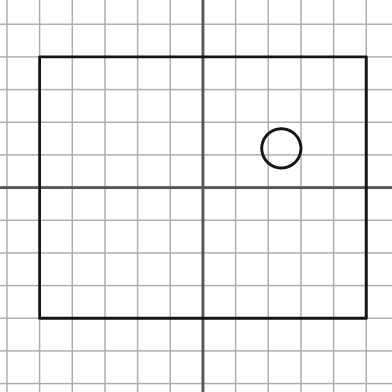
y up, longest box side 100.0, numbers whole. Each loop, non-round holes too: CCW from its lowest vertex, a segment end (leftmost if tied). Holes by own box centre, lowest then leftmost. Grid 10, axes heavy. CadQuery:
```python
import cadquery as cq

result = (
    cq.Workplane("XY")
    .moveTo(-50.0, -40.0)
    .lineTo(50.0, -40.0)
    .lineTo(50.0, 40.0)
    .lineTo(-50.0, 40.0)
    .close()
    .moveTo(24.0, 12.0)
    .circle(6.0)
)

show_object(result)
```